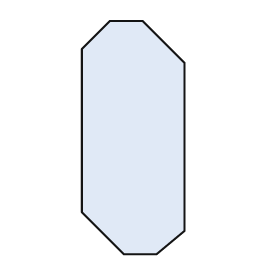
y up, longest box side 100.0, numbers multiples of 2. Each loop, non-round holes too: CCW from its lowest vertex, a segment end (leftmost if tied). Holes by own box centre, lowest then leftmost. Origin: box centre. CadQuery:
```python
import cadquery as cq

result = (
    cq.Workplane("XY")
    .moveTo(-4.0, -50.0)
    .lineTo(10.0, -50.0)
    .lineTo(22.0, -40.0)
    .lineTo(22.0, 32.0)
    .lineTo(4.0, 50.0)
    .lineTo(-10.0, 50.0)
    .lineTo(-22.0, 38.0)
    .lineTo(-22.0, -32.0)
    .close()
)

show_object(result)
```